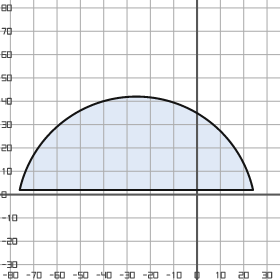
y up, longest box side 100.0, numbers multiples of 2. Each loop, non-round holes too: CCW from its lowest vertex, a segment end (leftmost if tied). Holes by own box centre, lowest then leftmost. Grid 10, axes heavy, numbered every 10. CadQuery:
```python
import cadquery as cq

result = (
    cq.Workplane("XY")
    .moveTo(-76.0, 2.0)
    .lineTo(24.0, 2.0)
    .threePointArc((-26.0, 42.0), (-76.0, 2.0))
    .close()
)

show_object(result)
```